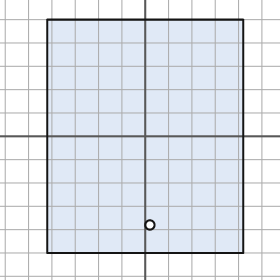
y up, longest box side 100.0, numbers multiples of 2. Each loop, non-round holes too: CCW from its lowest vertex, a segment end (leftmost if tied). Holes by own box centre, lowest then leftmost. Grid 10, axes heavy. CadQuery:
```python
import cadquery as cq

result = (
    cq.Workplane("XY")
    .moveTo(-42.0, -50.0)
    .lineTo(42.0, -50.0)
    .lineTo(42.0, 50.0)
    .lineTo(-42.0, 50.0)
    .close()
    .moveTo(2.0, -38.0)
    .circle(2.0)
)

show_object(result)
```